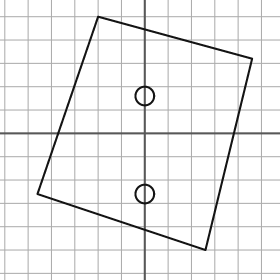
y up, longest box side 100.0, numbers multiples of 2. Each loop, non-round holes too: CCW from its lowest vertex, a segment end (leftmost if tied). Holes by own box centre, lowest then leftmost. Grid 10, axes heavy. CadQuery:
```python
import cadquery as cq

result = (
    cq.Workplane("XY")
    .moveTo(26.0, -50.0)
    .lineTo(46.0, 32.0)
    .lineTo(-20.0, 50.0)
    .lineTo(-46.0, -26.0)
    .close()
    .moveTo(0.0, -26.0)
    .circle(4.0)
    .moveTo(0.0, 16.0)
    .circle(4.0)
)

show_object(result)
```